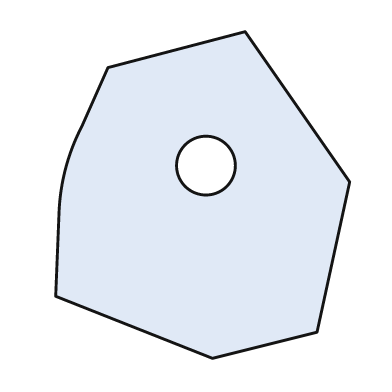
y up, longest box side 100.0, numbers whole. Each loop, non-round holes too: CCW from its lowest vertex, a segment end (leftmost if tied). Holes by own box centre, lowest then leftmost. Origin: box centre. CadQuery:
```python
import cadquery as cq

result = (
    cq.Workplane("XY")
    .moveTo(3.0, -50.0)
    .lineTo(35.0, -42.0)
    .lineTo(45.0, 4.0)
    .lineTo(13.0, 50.0)
    .lineTo(-29.0, 39.0)
    .lineTo(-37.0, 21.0)
    .threePointArc((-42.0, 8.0), (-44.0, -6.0))
    .lineTo(-45.0, -31.0)
    .close()
    .moveTo(1.0, 9.0)
    .circle(9.0)
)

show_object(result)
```